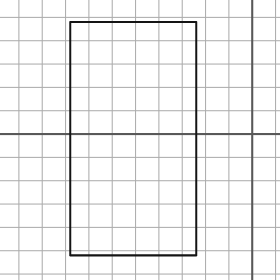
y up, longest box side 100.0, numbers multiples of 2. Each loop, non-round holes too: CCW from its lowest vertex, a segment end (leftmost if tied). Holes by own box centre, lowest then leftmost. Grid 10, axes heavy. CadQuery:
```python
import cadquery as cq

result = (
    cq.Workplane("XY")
    .moveTo(-78.0, -52.0)
    .lineTo(-24.0, -52.0)
    .lineTo(-24.0, 48.0)
    .lineTo(-78.0, 48.0)
    .close()
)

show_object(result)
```